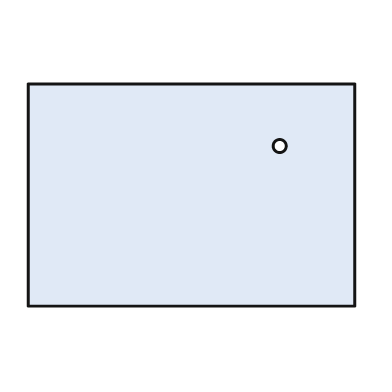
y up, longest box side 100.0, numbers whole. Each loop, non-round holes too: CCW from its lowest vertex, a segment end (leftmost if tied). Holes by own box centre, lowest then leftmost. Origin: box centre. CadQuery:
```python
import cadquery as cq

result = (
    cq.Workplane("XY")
    .moveTo(-50.0, -34.0)
    .lineTo(50.0, -34.0)
    .lineTo(50.0, 34.0)
    .lineTo(-50.0, 34.0)
    .close()
    .moveTo(27.0, 15.0)
    .circle(2.0)
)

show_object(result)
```